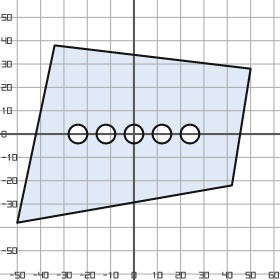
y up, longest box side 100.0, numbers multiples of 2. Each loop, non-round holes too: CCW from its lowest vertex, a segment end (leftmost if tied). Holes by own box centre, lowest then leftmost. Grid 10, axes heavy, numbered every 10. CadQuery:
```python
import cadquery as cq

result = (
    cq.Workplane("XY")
    .moveTo(-50.0, -38.0)
    .lineTo(42.0, -22.0)
    .lineTo(50.0, 28.0)
    .lineTo(-34.0, 38.0)
    .close()
    .moveTo(-24.0, 0.0)
    .circle(4.0)
    .moveTo(-12.0, 0.0)
    .circle(4.0)
    .moveTo(0.0, 0.0)
    .circle(4.0)
    .moveTo(12.0, 0.0)
    .circle(4.0)
    .moveTo(24.0, 0.0)
    .circle(4.0)
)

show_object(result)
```